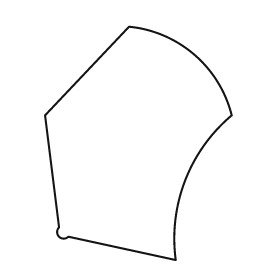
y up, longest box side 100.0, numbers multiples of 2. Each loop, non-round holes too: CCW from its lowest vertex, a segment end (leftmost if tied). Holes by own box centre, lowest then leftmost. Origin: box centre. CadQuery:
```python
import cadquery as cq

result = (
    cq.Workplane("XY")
    .moveTo(16.0, -50.0)
    .threePointArc((20.0, -16.0), (40.0, 12.0))
    .threePointArc((24.0, 38.0), (-4.0, 50.0))
    .lineTo(-40.0, 12.0)
    .lineTo(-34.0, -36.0)
    .threePointArc((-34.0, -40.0), (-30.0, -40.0))
    .close()
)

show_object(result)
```